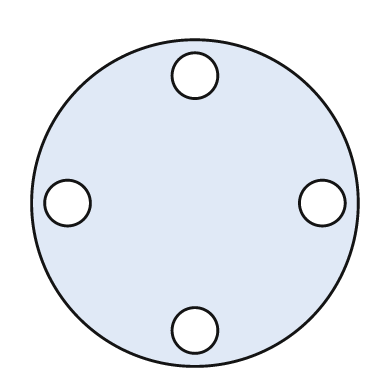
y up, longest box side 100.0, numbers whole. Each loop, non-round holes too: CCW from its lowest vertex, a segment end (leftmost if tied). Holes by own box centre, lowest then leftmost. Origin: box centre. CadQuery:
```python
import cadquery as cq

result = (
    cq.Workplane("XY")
    .moveTo(0.0, 0.0)
    .circle(50.0)
    .moveTo(0.0, -39.0)
    .circle(7.0)
    .moveTo(-39.0, 0.0)
    .circle(7.0)
    .moveTo(39.0, 0.0)
    .circle(7.0)
    .moveTo(0.0, 39.0)
    .circle(7.0)
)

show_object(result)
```